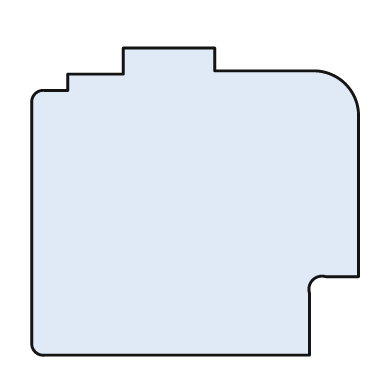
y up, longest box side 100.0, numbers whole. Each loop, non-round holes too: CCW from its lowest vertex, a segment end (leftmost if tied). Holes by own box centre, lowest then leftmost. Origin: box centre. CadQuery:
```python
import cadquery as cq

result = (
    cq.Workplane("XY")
    .moveTo(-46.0, -47.0)
    .lineTo(35.0, -47.0)
    .lineTo(35.0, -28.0)
    .threePointArc((36.0, -24.0), (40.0, -23.0))
    .lineTo(50.0, -23.0)
    .lineTo(50.0, 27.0)
    .threePointArc((46.0, 36.0), (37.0, 40.0))
    .lineTo(6.0, 40.0)
    .lineTo(6.0, 47.0)
    .lineTo(-22.0, 47.0)
    .lineTo(-22.0, 39.0)
    .lineTo(-39.0, 39.0)
    .lineTo(-39.0, 34.0)
    .lineTo(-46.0, 34.0)
    .threePointArc((-49.0, 33.0), (-50.0, 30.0))
    .lineTo(-50.0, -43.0)
    .threePointArc((-49.0, -46.0), (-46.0, -47.0))
    .close()
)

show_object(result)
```